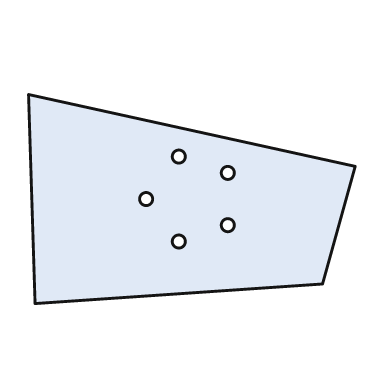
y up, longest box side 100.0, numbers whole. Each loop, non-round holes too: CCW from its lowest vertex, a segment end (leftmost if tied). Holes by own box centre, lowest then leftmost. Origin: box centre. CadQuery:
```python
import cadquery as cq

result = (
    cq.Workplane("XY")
    .moveTo(-48.0, -32.0)
    .lineTo(40.0, -26.0)
    .lineTo(50.0, 10.0)
    .lineTo(-50.0, 32.0)
    .close()
    .moveTo(-4.0, -13.0)
    .circle(2.0)
    .moveTo(11.0, -8.0)
    .circle(2.0)
    .moveTo(-14.0, 0.0)
    .circle(2.0)
    .moveTo(11.0, 8.0)
    .circle(2.0)
    .moveTo(-4.0, 13.0)
    .circle(2.0)
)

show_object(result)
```